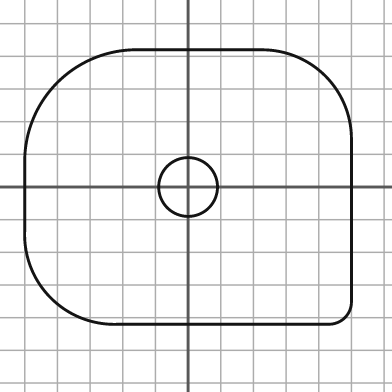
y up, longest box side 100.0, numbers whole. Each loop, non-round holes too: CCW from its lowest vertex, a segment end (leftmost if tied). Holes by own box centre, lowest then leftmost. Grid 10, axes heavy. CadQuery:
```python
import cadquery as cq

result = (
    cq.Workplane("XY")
    .moveTo(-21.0, -42.0)
    .lineTo(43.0, -42.0)
    .threePointArc((48.0, -40.0), (50.0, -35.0))
    .lineTo(50.0, 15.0)
    .threePointArc((42.0, 34.0), (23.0, 42.0))
    .lineTo(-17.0, 42.0)
    .threePointArc((-40.0, 32.0), (-50.0, 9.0))
    .lineTo(-50.0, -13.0)
    .threePointArc((-42.0, -34.0), (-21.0, -42.0))
    .close()
    .moveTo(0.0, 0.0)
    .circle(9.0)
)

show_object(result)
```